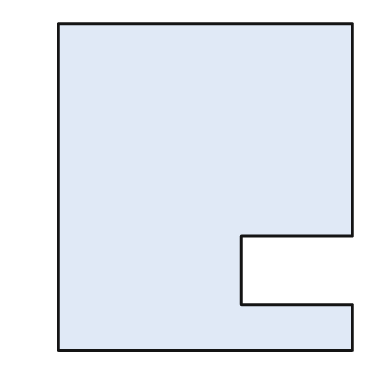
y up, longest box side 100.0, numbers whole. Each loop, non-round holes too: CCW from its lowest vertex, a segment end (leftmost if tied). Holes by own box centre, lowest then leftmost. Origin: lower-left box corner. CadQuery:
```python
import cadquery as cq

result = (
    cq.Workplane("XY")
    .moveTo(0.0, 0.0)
    .lineTo(90.0, 0.0)
    .lineTo(90.0, 14.0)
    .lineTo(56.0, 14.0)
    .lineTo(56.0, 35.0)
    .lineTo(90.0, 35.0)
    .lineTo(90.0, 100.0)
    .lineTo(0.0, 100.0)
    .close()
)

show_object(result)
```